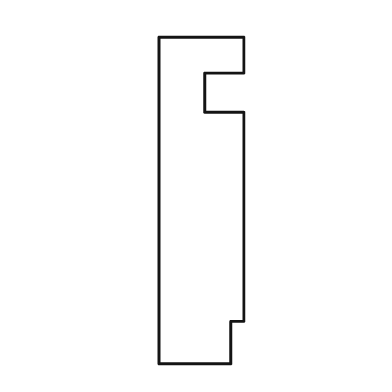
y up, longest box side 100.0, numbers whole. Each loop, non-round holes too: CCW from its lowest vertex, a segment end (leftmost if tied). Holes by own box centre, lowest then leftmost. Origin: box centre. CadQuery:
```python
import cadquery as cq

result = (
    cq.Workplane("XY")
    .moveTo(-13.0, -50.0)
    .lineTo(9.0, -50.0)
    .lineTo(9.0, -37.0)
    .lineTo(13.0, -37.0)
    .lineTo(13.0, 27.0)
    .lineTo(1.0, 27.0)
    .lineTo(1.0, 39.0)
    .lineTo(13.0, 39.0)
    .lineTo(13.0, 50.0)
    .lineTo(-13.0, 50.0)
    .close()
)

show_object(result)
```